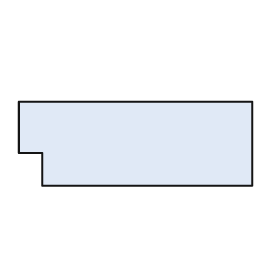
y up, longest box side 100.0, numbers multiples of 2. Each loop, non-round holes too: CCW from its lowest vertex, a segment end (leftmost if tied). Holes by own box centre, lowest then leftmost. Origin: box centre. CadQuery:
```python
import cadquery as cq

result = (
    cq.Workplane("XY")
    .moveTo(-40.0, -18.0)
    .lineTo(50.0, -18.0)
    .lineTo(50.0, 18.0)
    .lineTo(-50.0, 18.0)
    .lineTo(-50.0, -4.0)
    .lineTo(-40.0, -4.0)
    .close()
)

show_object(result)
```